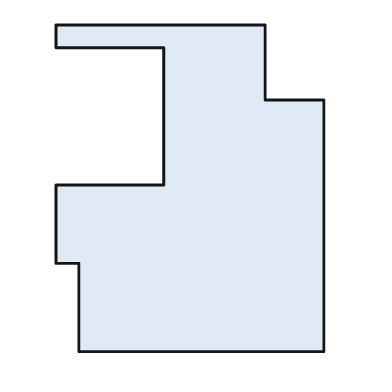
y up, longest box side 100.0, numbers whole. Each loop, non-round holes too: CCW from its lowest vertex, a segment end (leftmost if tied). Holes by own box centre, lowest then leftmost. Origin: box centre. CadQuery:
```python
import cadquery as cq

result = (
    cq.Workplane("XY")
    .moveTo(-34.0, -50.0)
    .lineTo(41.0, -50.0)
    .lineTo(41.0, 27.0)
    .lineTo(23.0, 27.0)
    .lineTo(23.0, 50.0)
    .lineTo(-41.0, 50.0)
    .lineTo(-41.0, 43.0)
    .lineTo(-8.0, 43.0)
    .lineTo(-8.0, 1.0)
    .lineTo(-41.0, 1.0)
    .lineTo(-41.0, -23.0)
    .lineTo(-34.0, -23.0)
    .close()
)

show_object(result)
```